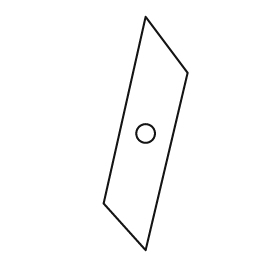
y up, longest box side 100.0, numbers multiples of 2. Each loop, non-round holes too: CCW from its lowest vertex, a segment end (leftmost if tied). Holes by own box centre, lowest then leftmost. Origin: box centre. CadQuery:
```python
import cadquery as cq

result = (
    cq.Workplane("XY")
    .moveTo(0.0, -50.0)
    .lineTo(18.0, 26.0)
    .lineTo(0.0, 50.0)
    .lineTo(-18.0, -30.0)
    .close()
    .moveTo(0.0, 0.0)
    .circle(4.0)
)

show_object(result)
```